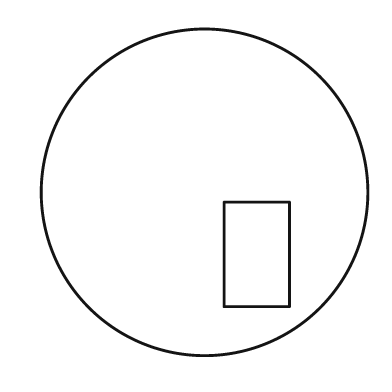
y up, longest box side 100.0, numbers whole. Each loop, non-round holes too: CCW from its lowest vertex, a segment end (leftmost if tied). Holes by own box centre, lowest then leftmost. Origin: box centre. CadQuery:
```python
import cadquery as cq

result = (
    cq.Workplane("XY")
    .moveTo(0.0, 0.0)
    .circle(50.0)
    .moveTo(6.0, -35.0)
    .lineTo(26.0, -35.0)
    .lineTo(26.0, -3.0)
    .lineTo(6.0, -3.0)
    .close()
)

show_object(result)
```